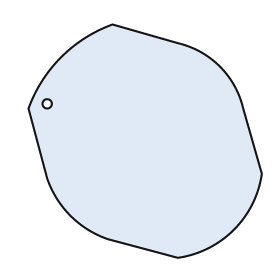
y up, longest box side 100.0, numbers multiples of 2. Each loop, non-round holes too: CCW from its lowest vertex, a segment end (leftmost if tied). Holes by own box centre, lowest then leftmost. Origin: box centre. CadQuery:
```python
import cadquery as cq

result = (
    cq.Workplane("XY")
    .moveTo(14.0, -50.0)
    .threePointArc((38.0, -38.0), (50.0, -14.0))
    .lineTo(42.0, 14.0)
    .threePointArc((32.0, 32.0), (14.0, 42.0))
    .lineTo(-14.0, 50.0)
    .threePointArc((-36.0, 36.0), (-50.0, 14.0))
    .lineTo(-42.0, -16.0)
    .threePointArc((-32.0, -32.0), (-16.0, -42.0))
    .close()
    .moveTo(-42.0, 16.0)
    .circle(2.0)
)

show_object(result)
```